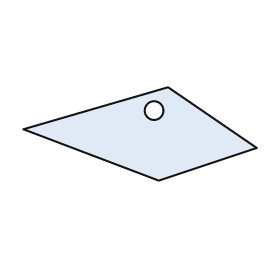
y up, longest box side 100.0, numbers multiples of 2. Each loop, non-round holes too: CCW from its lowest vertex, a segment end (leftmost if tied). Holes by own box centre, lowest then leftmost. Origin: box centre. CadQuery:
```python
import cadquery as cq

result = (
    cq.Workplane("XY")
    .moveTo(8.0, -20.0)
    .lineTo(50.0, -6.0)
    .lineTo(12.0, 20.0)
    .lineTo(-50.0, 2.0)
    .close()
    .moveTo(6.0, 10.0)
    .circle(4.0)
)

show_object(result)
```